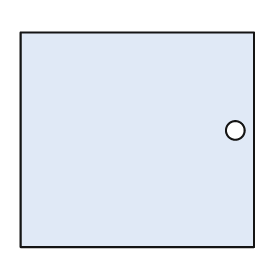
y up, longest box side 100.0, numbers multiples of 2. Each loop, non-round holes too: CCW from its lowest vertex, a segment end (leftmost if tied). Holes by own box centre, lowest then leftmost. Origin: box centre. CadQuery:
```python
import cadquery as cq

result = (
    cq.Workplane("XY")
    .moveTo(-50.0, -46.0)
    .lineTo(50.0, -46.0)
    .lineTo(50.0, 46.0)
    .lineTo(-50.0, 46.0)
    .close()
    .moveTo(42.0, 4.0)
    .circle(4.0)
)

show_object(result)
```